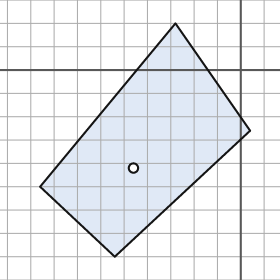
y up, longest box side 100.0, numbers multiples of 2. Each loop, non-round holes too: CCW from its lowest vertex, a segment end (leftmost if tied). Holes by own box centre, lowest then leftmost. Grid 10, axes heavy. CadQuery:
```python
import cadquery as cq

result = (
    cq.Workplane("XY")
    .moveTo(-54.0, -80.0)
    .lineTo(4.0, -26.0)
    .lineTo(-28.0, 20.0)
    .lineTo(-86.0, -50.0)
    .close()
    .moveTo(-46.0, -42.0)
    .circle(2.0)
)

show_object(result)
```